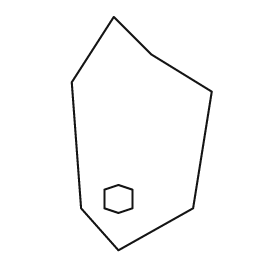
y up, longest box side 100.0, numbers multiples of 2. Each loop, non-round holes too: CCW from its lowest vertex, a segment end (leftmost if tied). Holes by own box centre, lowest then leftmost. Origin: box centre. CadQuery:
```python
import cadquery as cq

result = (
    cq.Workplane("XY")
    .moveTo(-10.0, -50.0)
    .lineTo(22.0, -32.0)
    .lineTo(30.0, 18.0)
    .lineTo(4.0, 34.0)
    .lineTo(-12.0, 50.0)
    .lineTo(-30.0, 22.0)
    .lineTo(-26.0, -32.0)
    .close()
    .moveTo(-10.0, -34.0)
    .lineTo(-4.0, -32.0)
    .lineTo(-4.0, -24.0)
    .lineTo(-10.0, -22.0)
    .lineTo(-16.0, -24.0)
    .lineTo(-16.0, -32.0)
    .close()
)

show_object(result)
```